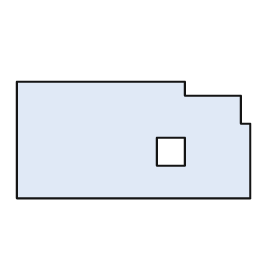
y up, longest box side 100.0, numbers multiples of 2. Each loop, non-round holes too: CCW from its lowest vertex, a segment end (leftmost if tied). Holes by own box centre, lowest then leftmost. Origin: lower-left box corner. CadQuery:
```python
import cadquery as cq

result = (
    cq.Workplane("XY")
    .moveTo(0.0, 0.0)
    .lineTo(100.0, 0.0)
    .lineTo(100.0, 32.0)
    .lineTo(96.0, 32.0)
    .lineTo(96.0, 44.0)
    .lineTo(72.0, 44.0)
    .lineTo(72.0, 50.0)
    .lineTo(0.0, 50.0)
    .close()
    .moveTo(60.0, 14.0)
    .lineTo(72.0, 14.0)
    .lineTo(72.0, 26.0)
    .lineTo(60.0, 26.0)
    .close()
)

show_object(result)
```